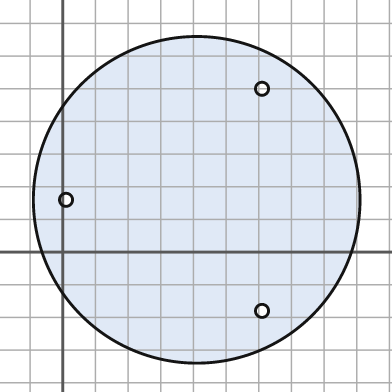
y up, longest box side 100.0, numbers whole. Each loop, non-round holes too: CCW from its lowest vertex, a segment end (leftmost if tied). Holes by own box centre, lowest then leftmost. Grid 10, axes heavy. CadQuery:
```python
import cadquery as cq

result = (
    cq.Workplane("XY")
    .moveTo(41.0, 16.0)
    .circle(50.0)
    .moveTo(61.0, -18.0)
    .circle(2.0)
    .moveTo(1.0, 16.0)
    .circle(2.0)
    .moveTo(61.0, 50.0)
    .circle(2.0)
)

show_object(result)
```